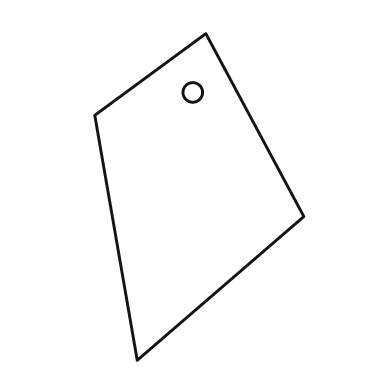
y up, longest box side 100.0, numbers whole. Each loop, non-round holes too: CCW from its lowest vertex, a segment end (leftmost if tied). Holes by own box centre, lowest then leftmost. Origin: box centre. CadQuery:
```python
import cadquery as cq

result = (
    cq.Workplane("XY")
    .moveTo(-19.0, -50.0)
    .lineTo(32.0, -6.0)
    .lineTo(2.0, 50.0)
    .lineTo(-32.0, 25.0)
    .close()
    .moveTo(-2.0, 32.0)
    .circle(3.0)
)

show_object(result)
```